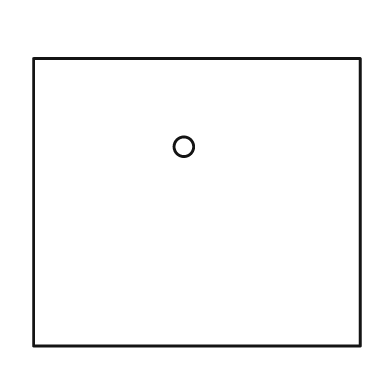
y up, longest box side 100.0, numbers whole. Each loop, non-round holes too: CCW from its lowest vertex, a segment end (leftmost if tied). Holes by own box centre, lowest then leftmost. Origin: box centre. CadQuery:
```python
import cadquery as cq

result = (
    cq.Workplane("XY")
    .moveTo(-50.0, -44.0)
    .lineTo(50.0, -44.0)
    .lineTo(50.0, 44.0)
    .lineTo(-50.0, 44.0)
    .close()
    .moveTo(-4.0, 17.0)
    .circle(3.0)
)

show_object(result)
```